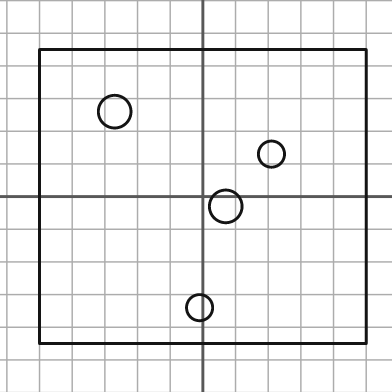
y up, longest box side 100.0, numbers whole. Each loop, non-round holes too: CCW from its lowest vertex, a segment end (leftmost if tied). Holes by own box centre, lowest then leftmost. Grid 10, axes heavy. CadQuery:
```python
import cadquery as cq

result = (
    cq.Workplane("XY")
    .moveTo(-50.0, -45.0)
    .lineTo(50.0, -45.0)
    .lineTo(50.0, 45.0)
    .lineTo(-50.0, 45.0)
    .close()
    .moveTo(-1.0, -34.0)
    .circle(4.0)
    .moveTo(7.0, -3.0)
    .circle(5.0)
    .moveTo(21.0, 13.0)
    .circle(4.0)
    .moveTo(-27.0, 26.0)
    .circle(5.0)
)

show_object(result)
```